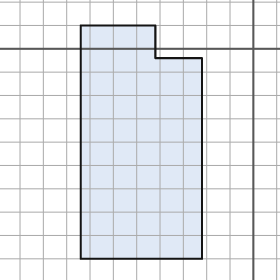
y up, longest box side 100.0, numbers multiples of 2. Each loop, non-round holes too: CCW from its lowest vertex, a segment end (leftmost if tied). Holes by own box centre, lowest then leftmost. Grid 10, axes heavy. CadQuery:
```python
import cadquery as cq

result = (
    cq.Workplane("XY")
    .moveTo(-74.0, -90.0)
    .lineTo(-22.0, -90.0)
    .lineTo(-22.0, -4.0)
    .lineTo(-42.0, -4.0)
    .lineTo(-42.0, 10.0)
    .lineTo(-74.0, 10.0)
    .close()
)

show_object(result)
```